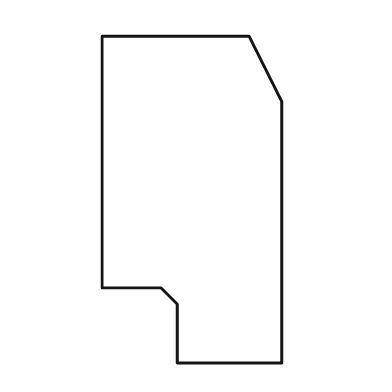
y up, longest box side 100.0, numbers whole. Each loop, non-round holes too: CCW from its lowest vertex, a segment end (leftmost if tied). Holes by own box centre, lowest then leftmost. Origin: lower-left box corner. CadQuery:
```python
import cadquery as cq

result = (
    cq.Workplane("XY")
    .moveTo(23.0, 0.0)
    .lineTo(55.0, 0.0)
    .lineTo(55.0, 80.0)
    .lineTo(45.0, 100.0)
    .lineTo(0.0, 100.0)
    .lineTo(0.0, 23.0)
    .lineTo(18.0, 23.0)
    .lineTo(23.0, 18.0)
    .close()
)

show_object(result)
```